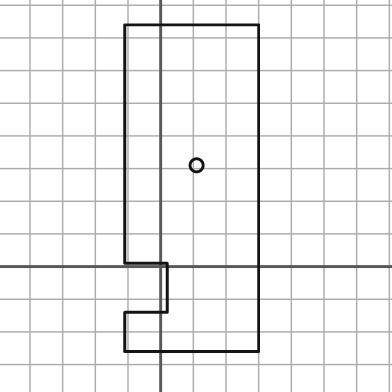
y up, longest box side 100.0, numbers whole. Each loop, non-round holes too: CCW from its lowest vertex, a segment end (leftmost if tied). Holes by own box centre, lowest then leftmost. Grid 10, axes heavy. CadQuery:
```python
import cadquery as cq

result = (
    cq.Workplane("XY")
    .moveTo(-11.0, -26.0)
    .lineTo(30.0, -26.0)
    .lineTo(30.0, 74.0)
    .lineTo(-11.0, 74.0)
    .lineTo(-11.0, 1.0)
    .lineTo(2.0, 1.0)
    .lineTo(2.0, -14.0)
    .lineTo(-11.0, -14.0)
    .close()
    .moveTo(11.0, 31.0)
    .circle(2.0)
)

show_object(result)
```